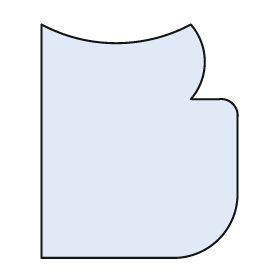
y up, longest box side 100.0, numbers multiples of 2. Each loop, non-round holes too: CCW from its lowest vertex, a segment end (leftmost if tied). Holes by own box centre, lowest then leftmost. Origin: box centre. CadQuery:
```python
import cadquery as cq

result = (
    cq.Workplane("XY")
    .moveTo(-42.0, -50.0)
    .lineTo(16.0, -50.0)
    .threePointArc((34.0, -42.0), (42.0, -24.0))
    .lineTo(42.0, 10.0)
    .threePointArc((40.0, 16.0), (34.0, 18.0))
    .lineTo(22.0, 18.0)
    .threePointArc((28.0, 34.0), (22.0, 50.0))
    .threePointArc((-10.0, 42.0), (-42.0, 50.0))
    .close()
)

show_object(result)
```